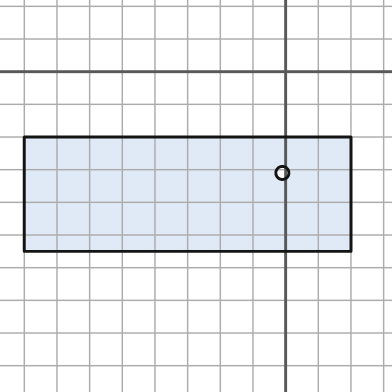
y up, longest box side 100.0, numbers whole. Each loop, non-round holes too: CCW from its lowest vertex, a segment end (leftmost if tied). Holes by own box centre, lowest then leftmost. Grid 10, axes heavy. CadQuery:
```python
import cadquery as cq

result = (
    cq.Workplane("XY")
    .moveTo(-80.0, -55.0)
    .lineTo(20.0, -55.0)
    .lineTo(20.0, -20.0)
    .lineTo(-80.0, -20.0)
    .close()
    .moveTo(-1.0, -31.0)
    .circle(2.0)
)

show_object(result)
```